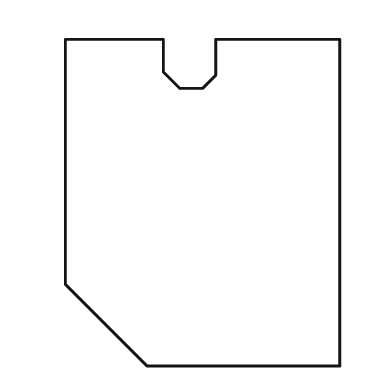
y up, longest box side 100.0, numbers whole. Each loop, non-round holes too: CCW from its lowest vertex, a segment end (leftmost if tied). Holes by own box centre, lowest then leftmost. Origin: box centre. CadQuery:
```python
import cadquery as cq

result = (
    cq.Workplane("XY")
    .moveTo(-17.0, -50.0)
    .lineTo(42.0, -50.0)
    .lineTo(42.0, 50.0)
    .lineTo(4.0, 50.0)
    .lineTo(4.0, 39.0)
    .lineTo(0.0, 35.0)
    .lineTo(-7.0, 35.0)
    .lineTo(-12.0, 40.0)
    .lineTo(-12.0, 50.0)
    .lineTo(-42.0, 50.0)
    .lineTo(-42.0, -25.0)
    .close()
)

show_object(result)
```